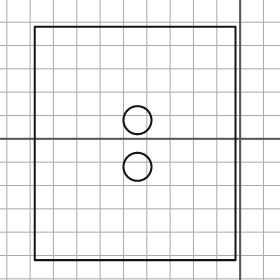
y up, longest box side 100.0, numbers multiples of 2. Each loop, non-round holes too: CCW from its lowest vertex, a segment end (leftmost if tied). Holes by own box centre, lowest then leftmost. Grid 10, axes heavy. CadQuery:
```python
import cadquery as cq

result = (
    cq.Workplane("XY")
    .moveTo(-88.0, -52.0)
    .lineTo(-2.0, -52.0)
    .lineTo(-2.0, 48.0)
    .lineTo(-88.0, 48.0)
    .close()
    .moveTo(-44.0, -12.0)
    .circle(6.0)
    .moveTo(-44.0, 8.0)
    .circle(6.0)
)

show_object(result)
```